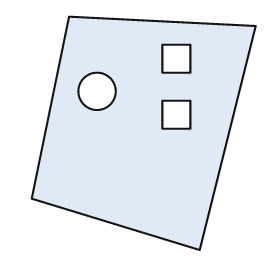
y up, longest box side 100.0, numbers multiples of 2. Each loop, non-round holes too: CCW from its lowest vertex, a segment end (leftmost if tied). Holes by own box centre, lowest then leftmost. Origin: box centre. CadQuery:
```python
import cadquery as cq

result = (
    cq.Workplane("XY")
    .moveTo(24.0, -50.0)
    .lineTo(48.0, 46.0)
    .lineTo(-32.0, 50.0)
    .lineTo(-48.0, -28.0)
    .close()
    .moveTo(8.0, 2.0)
    .lineTo(20.0, 2.0)
    .lineTo(20.0, 14.0)
    .lineTo(8.0, 14.0)
    .close()
    .moveTo(-20.0, 18.0)
    .circle(8.0)
    .moveTo(8.0, 26.0)
    .lineTo(20.0, 26.0)
    .lineTo(20.0, 38.0)
    .lineTo(8.0, 38.0)
    .close()
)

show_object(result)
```